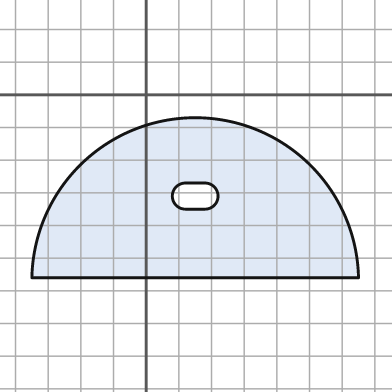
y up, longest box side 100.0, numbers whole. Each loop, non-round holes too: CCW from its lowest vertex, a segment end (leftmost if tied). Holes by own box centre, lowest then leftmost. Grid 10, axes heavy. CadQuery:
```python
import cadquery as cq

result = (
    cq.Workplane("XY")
    .moveTo(-35.0, -56.0)
    .lineTo(65.0, -56.0)
    .threePointArc((15.0, -7.0), (-35.0, -56.0))
    .close()
    .moveTo(12.0, -35.0)
    .lineTo(18.0, -35.0)
    .threePointArc((22.0, -31.0), (18.0, -27.0))
    .lineTo(12.0, -27.0)
    .threePointArc((8.0, -31.0), (12.0, -35.0))
    .close()
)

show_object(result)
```